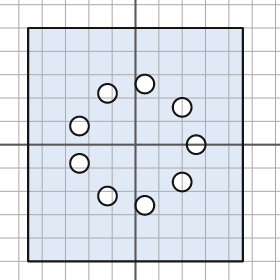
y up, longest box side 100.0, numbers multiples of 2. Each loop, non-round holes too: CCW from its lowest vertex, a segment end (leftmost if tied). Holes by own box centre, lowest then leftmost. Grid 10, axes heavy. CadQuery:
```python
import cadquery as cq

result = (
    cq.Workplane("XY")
    .moveTo(-46.0, -50.0)
    .lineTo(46.0, -50.0)
    .lineTo(46.0, 50.0)
    .lineTo(-46.0, 50.0)
    .close()
    .moveTo(4.0, -26.0)
    .circle(4.0)
    .moveTo(-12.0, -22.0)
    .circle(4.0)
    .moveTo(20.0, -16.0)
    .circle(4.0)
    .moveTo(-24.0, -8.0)
    .circle(4.0)
    .moveTo(26.0, 0.0)
    .circle(4.0)
    .moveTo(-24.0, 8.0)
    .circle(4.0)
    .moveTo(20.0, 16.0)
    .circle(4.0)
    .moveTo(-12.0, 22.0)
    .circle(4.0)
    .moveTo(4.0, 26.0)
    .circle(4.0)
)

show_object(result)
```